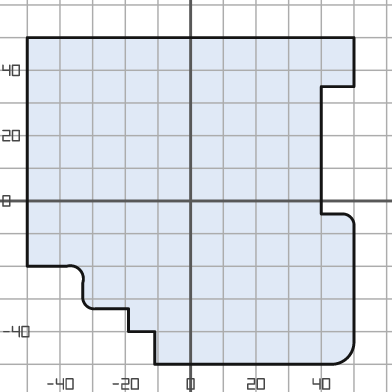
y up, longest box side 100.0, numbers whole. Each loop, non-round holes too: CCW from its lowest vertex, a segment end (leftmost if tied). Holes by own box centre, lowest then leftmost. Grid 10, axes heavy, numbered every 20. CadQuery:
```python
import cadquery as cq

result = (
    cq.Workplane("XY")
    .moveTo(-11.0, -50.0)
    .lineTo(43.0, -50.0)
    .threePointArc((48.0, -48.0), (50.0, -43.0))
    .lineTo(50.0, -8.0)
    .threePointArc((49.0, -5.0), (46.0, -4.0))
    .lineTo(40.0, -4.0)
    .lineTo(40.0, 35.0)
    .lineTo(50.0, 35.0)
    .lineTo(50.0, 50.0)
    .lineTo(-50.0, 50.0)
    .lineTo(-50.0, -20.0)
    .lineTo(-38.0, -20.0)
    .threePointArc((-34.0, -21.0), (-33.0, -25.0))
    .lineTo(-33.0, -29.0)
    .threePointArc((-32.0, -32.0), (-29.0, -33.0))
    .lineTo(-19.0, -33.0)
    .lineTo(-19.0, -40.0)
    .lineTo(-11.0, -40.0)
    .close()
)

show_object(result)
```